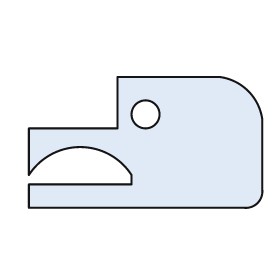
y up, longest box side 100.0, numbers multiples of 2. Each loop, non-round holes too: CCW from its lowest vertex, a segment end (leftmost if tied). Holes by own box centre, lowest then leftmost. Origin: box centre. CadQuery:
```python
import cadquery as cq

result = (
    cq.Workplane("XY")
    .moveTo(-50.0, -28.0)
    .lineTo(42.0, -28.0)
    .threePointArc((48.0, -26.0), (50.0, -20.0))
    .lineTo(50.0, 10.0)
    .threePointArc((44.0, 22.0), (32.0, 28.0))
    .lineTo(-12.0, 28.0)
    .lineTo(-12.0, 6.0)
    .lineTo(-50.0, 6.0)
    .lineTo(-50.0, -14.0)
    .threePointArc((-28.0, -2.0), (-6.0, -14.0))
    .lineTo(-6.0, -18.0)
    .lineTo(-50.0, -18.0)
    .close()
    .moveTo(0.0, 12.0)
    .circle(6.0)
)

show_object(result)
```